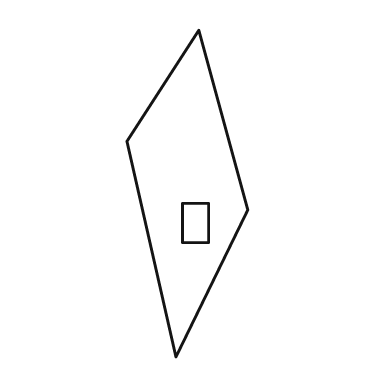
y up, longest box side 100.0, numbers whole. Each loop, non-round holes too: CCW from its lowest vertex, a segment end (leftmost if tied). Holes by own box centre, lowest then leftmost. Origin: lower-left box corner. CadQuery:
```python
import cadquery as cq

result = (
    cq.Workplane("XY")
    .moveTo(15.0, 0.0)
    .lineTo(37.0, 45.0)
    .lineTo(22.0, 100.0)
    .lineTo(0.0, 66.0)
    .close()
    .moveTo(17.0, 35.0)
    .lineTo(25.0, 35.0)
    .lineTo(25.0, 47.0)
    .lineTo(17.0, 47.0)
    .close()
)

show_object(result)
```